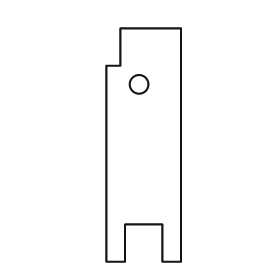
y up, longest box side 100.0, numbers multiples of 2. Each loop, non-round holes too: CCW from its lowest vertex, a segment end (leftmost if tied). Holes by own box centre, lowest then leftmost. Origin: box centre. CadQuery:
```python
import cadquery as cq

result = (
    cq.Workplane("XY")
    .moveTo(-16.0, -50.0)
    .lineTo(-8.0, -50.0)
    .lineTo(-8.0, -34.0)
    .lineTo(8.0, -34.0)
    .lineTo(8.0, -50.0)
    .lineTo(16.0, -50.0)
    .lineTo(16.0, 50.0)
    .lineTo(-10.0, 50.0)
    .lineTo(-10.0, 34.0)
    .lineTo(-16.0, 34.0)
    .close()
    .moveTo(-2.0, 26.0)
    .circle(4.0)
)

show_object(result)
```